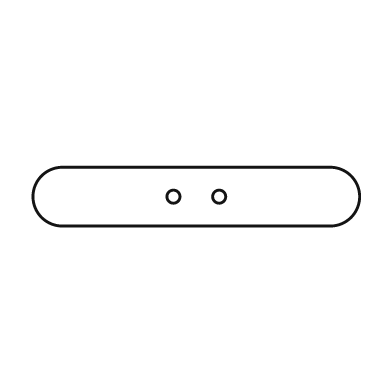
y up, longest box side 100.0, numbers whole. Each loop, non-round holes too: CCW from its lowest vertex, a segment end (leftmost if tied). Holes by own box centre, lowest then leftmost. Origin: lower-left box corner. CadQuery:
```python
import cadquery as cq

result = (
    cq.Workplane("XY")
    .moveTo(9.0, 0.0)
    .lineTo(91.0, 0.0)
    .threePointArc((100.0, 9.0), (91.0, 18.0))
    .lineTo(9.0, 18.0)
    .threePointArc((0.0, 9.0), (9.0, 0.0))
    .close()
    .moveTo(43.0, 9.0)
    .circle(2.0)
    .moveTo(57.0, 9.0)
    .circle(2.0)
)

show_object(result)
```